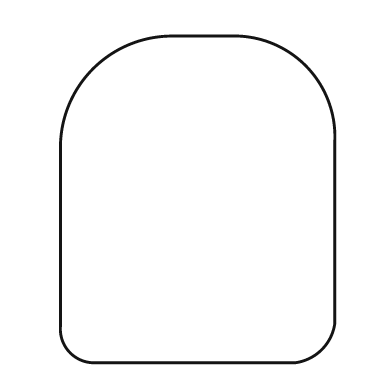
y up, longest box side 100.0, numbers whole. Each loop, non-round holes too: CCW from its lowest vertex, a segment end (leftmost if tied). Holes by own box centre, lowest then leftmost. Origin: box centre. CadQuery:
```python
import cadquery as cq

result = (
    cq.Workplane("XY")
    .moveTo(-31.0, -50.0)
    .lineTo(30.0, -50.0)
    .threePointArc((38.0, -46.0), (42.0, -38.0))
    .lineTo(42.0, 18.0)
    .threePointArc((33.0, 41.0), (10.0, 50.0))
    .lineTo(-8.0, 50.0)
    .threePointArc((-32.0, 40.0), (-42.0, 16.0))
    .lineTo(-42.0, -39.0)
    .threePointArc((-39.0, -47.0), (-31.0, -50.0))
    .close()
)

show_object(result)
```